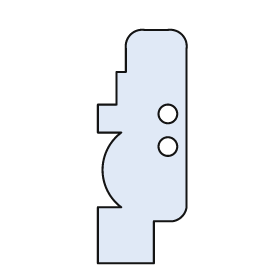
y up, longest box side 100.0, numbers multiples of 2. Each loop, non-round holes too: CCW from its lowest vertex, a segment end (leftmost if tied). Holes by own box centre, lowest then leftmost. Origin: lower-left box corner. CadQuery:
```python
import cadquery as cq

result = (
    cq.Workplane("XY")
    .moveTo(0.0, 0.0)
    .lineTo(24.0, 0.0)
    .lineTo(24.0, 18.0)
    .lineTo(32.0, 18.0)
    .threePointArc((36.0, 20.0), (38.0, 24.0))
    .lineTo(38.0, 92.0)
    .threePointArc((36.0, 98.0), (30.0, 100.0))
    .lineTo(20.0, 100.0)
    .threePointArc((14.0, 98.0), (12.0, 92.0))
    .lineTo(12.0, 82.0)
    .lineTo(8.0, 82.0)
    .lineTo(8.0, 68.0)
    .lineTo(0.0, 68.0)
    .lineTo(0.0, 56.0)
    .lineTo(10.0, 56.0)
    .threePointArc((2.0, 40.0), (10.0, 24.0))
    .lineTo(0.0, 24.0)
    .close()
    .moveTo(30.0, 50.0)
    .circle(4.0)
    .moveTo(30.0, 64.0)
    .circle(4.0)
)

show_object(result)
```